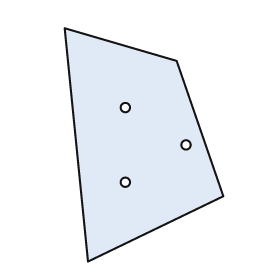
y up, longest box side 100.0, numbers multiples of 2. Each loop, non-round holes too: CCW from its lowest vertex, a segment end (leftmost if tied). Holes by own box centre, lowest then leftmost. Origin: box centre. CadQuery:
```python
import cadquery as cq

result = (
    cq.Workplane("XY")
    .moveTo(-24.0, -50.0)
    .lineTo(34.0, -22.0)
    .lineTo(14.0, 36.0)
    .lineTo(-34.0, 50.0)
    .close()
    .moveTo(-8.0, -16.0)
    .circle(2.0)
    .moveTo(18.0, 0.0)
    .circle(2.0)
    .moveTo(-8.0, 16.0)
    .circle(2.0)
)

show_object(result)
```